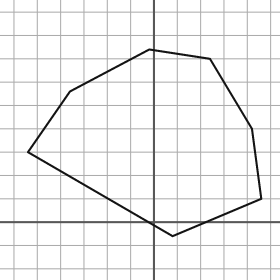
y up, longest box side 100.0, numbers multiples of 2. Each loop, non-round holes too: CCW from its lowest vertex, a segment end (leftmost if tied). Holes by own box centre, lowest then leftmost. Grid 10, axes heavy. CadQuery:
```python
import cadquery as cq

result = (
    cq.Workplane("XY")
    .moveTo(8.0, -6.0)
    .lineTo(46.0, 10.0)
    .lineTo(42.0, 40.0)
    .lineTo(24.0, 70.0)
    .lineTo(-2.0, 74.0)
    .lineTo(-36.0, 56.0)
    .lineTo(-54.0, 30.0)
    .close()
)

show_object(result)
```